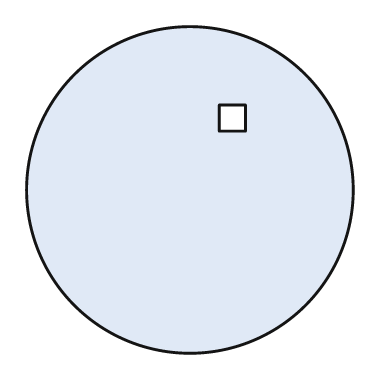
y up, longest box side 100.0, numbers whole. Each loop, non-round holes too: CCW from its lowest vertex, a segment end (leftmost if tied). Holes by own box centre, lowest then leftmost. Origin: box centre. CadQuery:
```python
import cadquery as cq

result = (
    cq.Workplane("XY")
    .moveTo(0.0, 0.0)
    .circle(50.0)
    .moveTo(9.0, 18.0)
    .lineTo(17.0, 18.0)
    .lineTo(17.0, 26.0)
    .lineTo(9.0, 26.0)
    .close()
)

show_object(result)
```